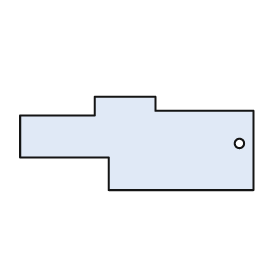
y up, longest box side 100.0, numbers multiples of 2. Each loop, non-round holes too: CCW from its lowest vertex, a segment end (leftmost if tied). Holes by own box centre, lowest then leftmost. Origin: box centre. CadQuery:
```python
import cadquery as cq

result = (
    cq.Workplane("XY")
    .moveTo(-12.0, -20.0)
    .lineTo(50.0, -20.0)
    .lineTo(50.0, 14.0)
    .lineTo(8.0, 14.0)
    .lineTo(8.0, 20.0)
    .lineTo(-18.0, 20.0)
    .lineTo(-18.0, 12.0)
    .lineTo(-50.0, 12.0)
    .lineTo(-50.0, -6.0)
    .lineTo(-12.0, -6.0)
    .close()
    .moveTo(44.0, 0.0)
    .circle(2.0)
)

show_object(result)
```